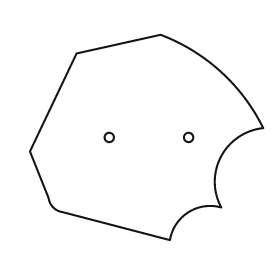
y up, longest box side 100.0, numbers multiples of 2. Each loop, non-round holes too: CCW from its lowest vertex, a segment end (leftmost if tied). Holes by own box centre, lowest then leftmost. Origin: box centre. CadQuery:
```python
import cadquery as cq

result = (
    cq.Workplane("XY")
    .moveTo(10.0, -44.0)
    .threePointArc((18.0, -32.0), (32.0, -30.0))
    .threePointArc((32.0, -8.0), (50.0, 4.0))
    .threePointArc((32.0, 28.0), (6.0, 44.0))
    .lineTo(-30.0, 36.0)
    .lineTo(-50.0, -6.0)
    .lineTo(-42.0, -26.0)
    .threePointArc((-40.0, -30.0), (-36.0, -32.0))
    .close()
    .moveTo(-16.0, 0.0)
    .circle(2.0)
    .moveTo(18.0, 0.0)
    .circle(2.0)
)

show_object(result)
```